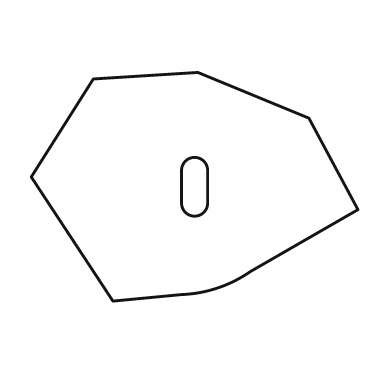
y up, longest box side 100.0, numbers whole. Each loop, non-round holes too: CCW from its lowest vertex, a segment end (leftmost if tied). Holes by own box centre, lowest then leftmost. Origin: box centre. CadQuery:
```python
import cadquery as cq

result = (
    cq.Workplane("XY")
    .moveTo(-25.0, -35.0)
    .lineTo(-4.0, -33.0)
    .threePointArc((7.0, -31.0), (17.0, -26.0))
    .lineTo(50.0, -7.0)
    .lineTo(35.0, 21.0)
    .lineTo(1.0, 35.0)
    .lineTo(-31.0, 33.0)
    .lineTo(-50.0, 3.0)
    .close()
    .moveTo(-4.0, -5.0)
    .threePointArc((0.0, -9.0), (4.0, -5.0))
    .lineTo(4.0, 5.0)
    .threePointArc((0.0, 9.0), (-4.0, 5.0))
    .close()
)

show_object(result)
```